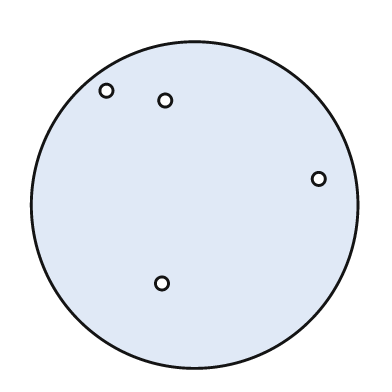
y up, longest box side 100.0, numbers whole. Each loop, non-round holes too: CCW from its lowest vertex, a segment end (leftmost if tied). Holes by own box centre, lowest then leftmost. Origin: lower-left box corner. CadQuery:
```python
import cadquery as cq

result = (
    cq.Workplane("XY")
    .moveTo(50.0, 50.0)
    .circle(50.0)
    .moveTo(40.0, 26.0)
    .circle(2.0)
    .moveTo(88.0, 58.0)
    .circle(2.0)
    .moveTo(41.0, 82.0)
    .circle(2.0)
    .moveTo(23.0, 85.0)
    .circle(2.0)
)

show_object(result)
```